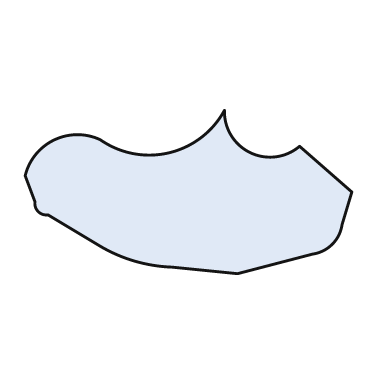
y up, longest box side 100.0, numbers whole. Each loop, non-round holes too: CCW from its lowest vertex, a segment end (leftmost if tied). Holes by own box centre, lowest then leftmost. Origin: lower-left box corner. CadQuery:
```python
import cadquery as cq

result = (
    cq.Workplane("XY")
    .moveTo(65.0, 0.0)
    .lineTo(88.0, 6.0)
    .threePointArc((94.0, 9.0), (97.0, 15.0))
    .lineTo(100.0, 25.0)
    .lineTo(84.0, 39.0)
    .threePointArc((69.0, 37.0), (61.0, 50.0))
    .threePointArc((44.0, 37.0), (23.0, 41.0))
    .threePointArc((9.0, 41.0), (0.0, 30.0))
    .lineTo(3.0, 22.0)
    .threePointArc((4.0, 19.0), (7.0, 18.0))
    .lineTo(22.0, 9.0)
    .threePointArc((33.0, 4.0), (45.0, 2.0))
    .close()
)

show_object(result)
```